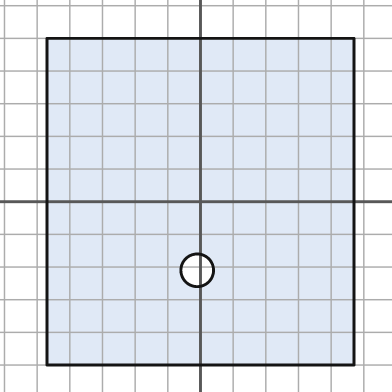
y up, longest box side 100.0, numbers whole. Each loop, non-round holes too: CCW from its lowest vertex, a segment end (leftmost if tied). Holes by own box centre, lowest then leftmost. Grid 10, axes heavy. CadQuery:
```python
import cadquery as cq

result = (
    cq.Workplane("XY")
    .moveTo(-47.0, -50.0)
    .lineTo(47.0, -50.0)
    .lineTo(47.0, 50.0)
    .lineTo(-47.0, 50.0)
    .close()
    .moveTo(-1.0, -21.0)
    .circle(5.0)
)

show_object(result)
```